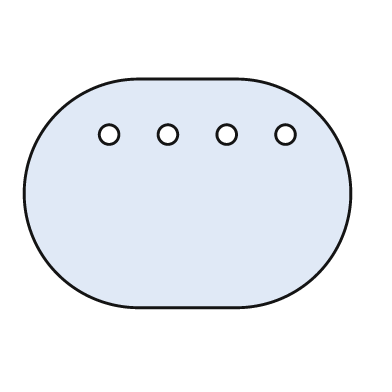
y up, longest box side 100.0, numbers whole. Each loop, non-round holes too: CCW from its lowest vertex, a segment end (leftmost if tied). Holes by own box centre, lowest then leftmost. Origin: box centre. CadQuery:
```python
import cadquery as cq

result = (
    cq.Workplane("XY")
    .moveTo(-15.0, -35.0)
    .lineTo(15.0, -35.0)
    .threePointArc((50.0, 0.0), (15.0, 35.0))
    .lineTo(-15.0, 35.0)
    .threePointArc((-50.0, 0.0), (-15.0, -35.0))
    .close()
    .moveTo(-24.0, 18.0)
    .circle(3.0)
    .moveTo(-6.0, 18.0)
    .circle(3.0)
    .moveTo(12.0, 18.0)
    .circle(3.0)
    .moveTo(30.0, 18.0)
    .circle(3.0)
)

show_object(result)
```